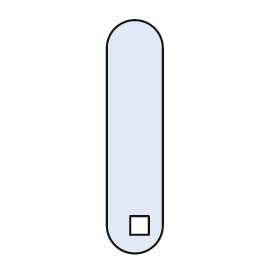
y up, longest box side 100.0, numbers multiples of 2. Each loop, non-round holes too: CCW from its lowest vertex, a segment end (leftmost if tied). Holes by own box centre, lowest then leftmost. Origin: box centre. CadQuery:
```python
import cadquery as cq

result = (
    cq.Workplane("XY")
    .moveTo(-12.0, -38.0)
    .threePointArc((0.0, -50.0), (12.0, -38.0))
    .lineTo(12.0, 38.0)
    .threePointArc((0.0, 50.0), (-12.0, 38.0))
    .close()
    .moveTo(-2.0, -42.0)
    .lineTo(6.0, -42.0)
    .lineTo(6.0, -34.0)
    .lineTo(-2.0, -34.0)
    .close()
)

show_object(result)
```